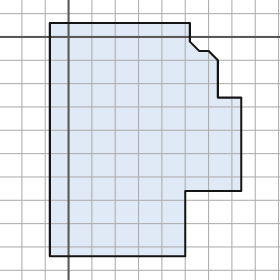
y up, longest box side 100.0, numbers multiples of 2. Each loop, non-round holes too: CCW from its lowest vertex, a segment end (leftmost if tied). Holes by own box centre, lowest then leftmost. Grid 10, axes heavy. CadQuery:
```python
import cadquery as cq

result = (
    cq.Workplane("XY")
    .moveTo(-8.0, -94.0)
    .lineTo(50.0, -94.0)
    .lineTo(50.0, -66.0)
    .lineTo(74.0, -66.0)
    .lineTo(74.0, -26.0)
    .lineTo(64.0, -26.0)
    .lineTo(64.0, -10.0)
    .lineTo(60.0, -6.0)
    .lineTo(56.0, -6.0)
    .lineTo(52.0, -2.0)
    .lineTo(52.0, 6.0)
    .lineTo(-8.0, 6.0)
    .close()
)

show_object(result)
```